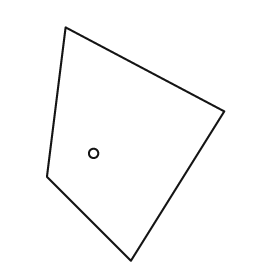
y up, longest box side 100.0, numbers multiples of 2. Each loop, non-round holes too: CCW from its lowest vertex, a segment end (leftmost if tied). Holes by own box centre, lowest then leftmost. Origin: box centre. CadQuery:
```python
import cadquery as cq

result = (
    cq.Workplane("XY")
    .moveTo(-2.0, -50.0)
    .lineTo(38.0, 14.0)
    .lineTo(-30.0, 50.0)
    .lineTo(-38.0, -14.0)
    .close()
    .moveTo(-18.0, -4.0)
    .circle(2.0)
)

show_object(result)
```